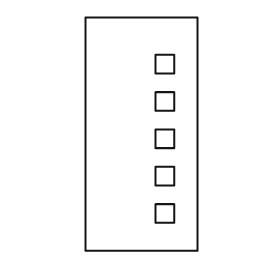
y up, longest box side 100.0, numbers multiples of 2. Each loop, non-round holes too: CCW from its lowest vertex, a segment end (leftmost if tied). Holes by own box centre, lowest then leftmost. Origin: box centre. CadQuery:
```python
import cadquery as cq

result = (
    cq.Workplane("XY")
    .moveTo(-24.0, -50.0)
    .lineTo(24.0, -50.0)
    .lineTo(24.0, 50.0)
    .lineTo(-24.0, 50.0)
    .close()
    .moveTo(6.0, -38.0)
    .lineTo(14.0, -38.0)
    .lineTo(14.0, -30.0)
    .lineTo(6.0, -30.0)
    .close()
    .moveTo(6.0, -22.0)
    .lineTo(14.0, -22.0)
    .lineTo(14.0, -14.0)
    .lineTo(6.0, -14.0)
    .close()
    .moveTo(6.0, -6.0)
    .lineTo(14.0, -6.0)
    .lineTo(14.0, 2.0)
    .lineTo(6.0, 2.0)
    .close()
    .moveTo(6.0, 10.0)
    .lineTo(14.0, 10.0)
    .lineTo(14.0, 18.0)
    .lineTo(6.0, 18.0)
    .close()
    .moveTo(6.0, 26.0)
    .lineTo(14.0, 26.0)
    .lineTo(14.0, 34.0)
    .lineTo(6.0, 34.0)
    .close()
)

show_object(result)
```